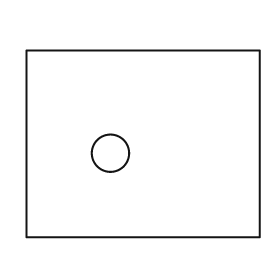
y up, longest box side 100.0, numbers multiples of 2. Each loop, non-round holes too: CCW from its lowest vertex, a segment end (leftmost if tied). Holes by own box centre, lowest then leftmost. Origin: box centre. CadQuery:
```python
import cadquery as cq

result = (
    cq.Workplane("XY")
    .moveTo(-50.0, -40.0)
    .lineTo(50.0, -40.0)
    .lineTo(50.0, 40.0)
    .lineTo(-50.0, 40.0)
    .close()
    .moveTo(-14.0, -4.0)
    .circle(8.0)
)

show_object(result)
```